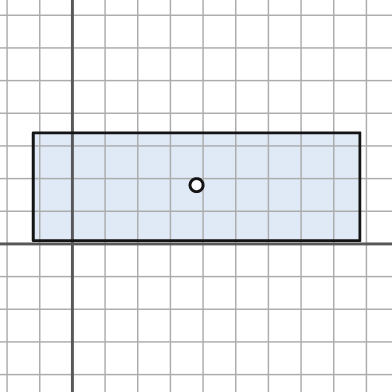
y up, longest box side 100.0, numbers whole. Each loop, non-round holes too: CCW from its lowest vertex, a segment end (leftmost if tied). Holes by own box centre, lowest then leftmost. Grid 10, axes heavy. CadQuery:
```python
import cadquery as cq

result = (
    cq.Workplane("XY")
    .moveTo(-12.0, 1.0)
    .lineTo(88.0, 1.0)
    .lineTo(88.0, 34.0)
    .lineTo(-12.0, 34.0)
    .close()
    .moveTo(38.0, 18.0)
    .circle(2.0)
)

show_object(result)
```